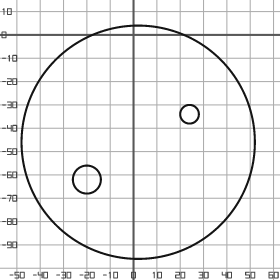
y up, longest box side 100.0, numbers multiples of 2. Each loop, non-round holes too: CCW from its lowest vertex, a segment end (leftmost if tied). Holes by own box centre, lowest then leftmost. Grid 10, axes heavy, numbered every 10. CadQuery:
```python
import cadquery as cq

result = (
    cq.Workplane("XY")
    .moveTo(2.0, -46.0)
    .circle(50.0)
    .moveTo(-20.0, -62.0)
    .circle(6.0)
    .moveTo(24.0, -34.0)
    .circle(4.0)
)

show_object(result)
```